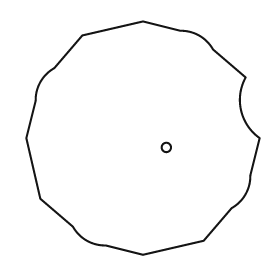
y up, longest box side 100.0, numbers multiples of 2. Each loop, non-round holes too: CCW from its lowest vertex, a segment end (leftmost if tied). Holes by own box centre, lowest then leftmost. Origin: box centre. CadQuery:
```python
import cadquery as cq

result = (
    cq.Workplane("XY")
    .moveTo(0.0, -50.0)
    .lineTo(26.0, -44.0)
    .lineTo(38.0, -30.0)
    .threePointArc((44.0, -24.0), (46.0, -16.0))
    .lineTo(50.0, 0.0)
    .threePointArc((42.0, 12.0), (44.0, 26.0))
    .lineTo(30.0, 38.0)
    .threePointArc((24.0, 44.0), (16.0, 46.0))
    .lineTo(0.0, 50.0)
    .lineTo(-26.0, 44.0)
    .lineTo(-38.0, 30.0)
    .threePointArc((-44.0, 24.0), (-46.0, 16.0))
    .lineTo(-50.0, 0.0)
    .lineTo(-44.0, -26.0)
    .lineTo(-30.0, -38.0)
    .threePointArc((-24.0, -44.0), (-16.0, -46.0))
    .close()
    .moveTo(10.0, -4.0)
    .circle(2.0)
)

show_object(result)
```